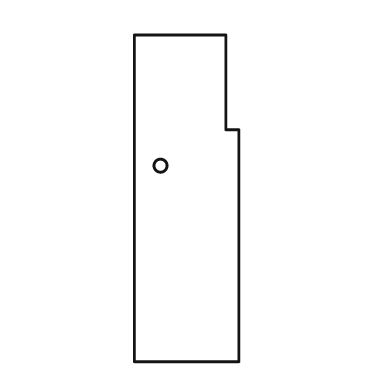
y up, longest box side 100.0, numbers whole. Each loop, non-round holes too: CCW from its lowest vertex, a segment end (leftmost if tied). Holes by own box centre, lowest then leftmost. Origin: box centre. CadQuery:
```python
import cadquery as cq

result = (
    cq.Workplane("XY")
    .moveTo(-16.0, -50.0)
    .lineTo(16.0, -50.0)
    .lineTo(16.0, 21.0)
    .lineTo(12.0, 21.0)
    .lineTo(12.0, 50.0)
    .lineTo(-16.0, 50.0)
    .close()
    .moveTo(-8.0, 10.0)
    .circle(2.0)
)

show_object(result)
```